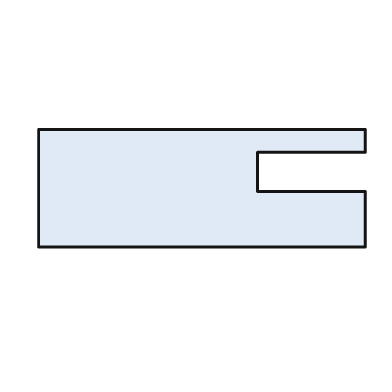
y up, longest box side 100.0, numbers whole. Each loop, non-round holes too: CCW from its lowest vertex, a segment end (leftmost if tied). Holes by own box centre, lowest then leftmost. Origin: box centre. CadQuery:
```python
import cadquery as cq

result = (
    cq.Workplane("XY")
    .moveTo(-50.0, -18.0)
    .lineTo(50.0, -18.0)
    .lineTo(50.0, -1.0)
    .lineTo(17.0, -1.0)
    .lineTo(17.0, 11.0)
    .lineTo(50.0, 11.0)
    .lineTo(50.0, 18.0)
    .lineTo(-50.0, 18.0)
    .close()
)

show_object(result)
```